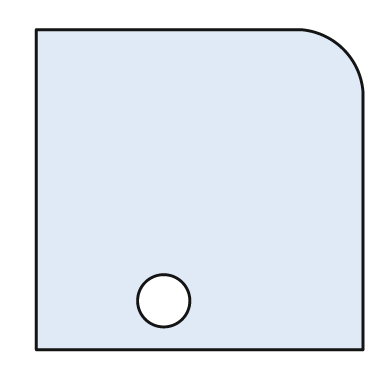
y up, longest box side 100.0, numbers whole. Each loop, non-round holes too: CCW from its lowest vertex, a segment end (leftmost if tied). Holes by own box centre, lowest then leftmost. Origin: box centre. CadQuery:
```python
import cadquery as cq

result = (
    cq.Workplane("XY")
    .moveTo(-50.0, -49.0)
    .lineTo(50.0, -49.0)
    .lineTo(50.0, 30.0)
    .threePointArc((44.0, 43.0), (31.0, 49.0))
    .lineTo(-50.0, 49.0)
    .close()
    .moveTo(-11.0, -34.0)
    .circle(8.0)
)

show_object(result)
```